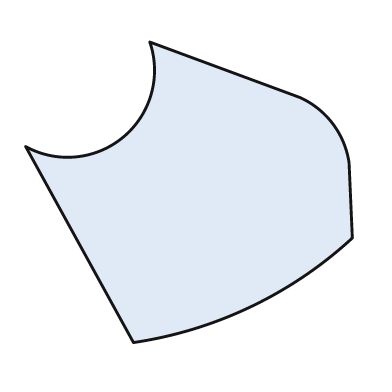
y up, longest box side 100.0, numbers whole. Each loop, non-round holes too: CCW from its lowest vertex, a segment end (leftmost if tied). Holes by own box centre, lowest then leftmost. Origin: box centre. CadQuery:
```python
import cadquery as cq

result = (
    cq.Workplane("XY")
    .moveTo(-17.0, -46.0)
    .threePointArc((19.0, -35.0), (50.0, -14.0))
    .lineTo(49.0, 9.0)
    .threePointArc((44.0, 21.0), (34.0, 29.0))
    .lineTo(-12.0, 46.0)
    .threePointArc((-20.0, 17.0), (-50.0, 14.0))
    .close()
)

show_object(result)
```